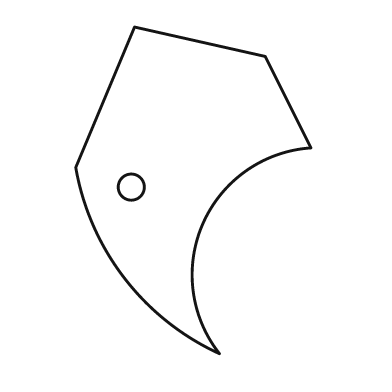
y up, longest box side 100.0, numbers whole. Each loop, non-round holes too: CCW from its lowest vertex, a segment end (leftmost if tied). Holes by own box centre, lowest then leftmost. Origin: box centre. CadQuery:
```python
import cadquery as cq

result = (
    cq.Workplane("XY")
    .moveTo(8.0, -50.0)
    .threePointArc((3.0, -10.0), (36.0, 13.0))
    .lineTo(22.0, 41.0)
    .lineTo(-18.0, 50.0)
    .lineTo(-36.0, 7.0)
    .threePointArc((-21.0, -27.0), (8.0, -50.0))
    .close()
    .moveTo(-19.0, 1.0)
    .circle(4.0)
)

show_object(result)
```